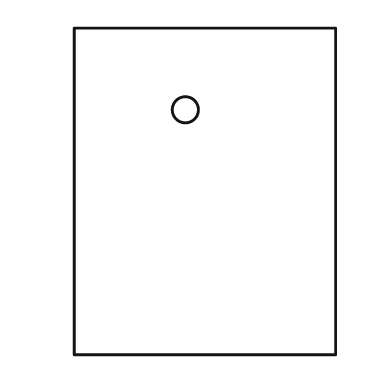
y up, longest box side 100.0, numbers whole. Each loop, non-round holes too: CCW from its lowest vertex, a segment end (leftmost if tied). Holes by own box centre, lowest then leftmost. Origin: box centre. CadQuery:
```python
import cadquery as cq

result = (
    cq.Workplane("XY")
    .moveTo(-40.0, -50.0)
    .lineTo(40.0, -50.0)
    .lineTo(40.0, 50.0)
    .lineTo(-40.0, 50.0)
    .close()
    .moveTo(-6.0, 25.0)
    .circle(4.0)
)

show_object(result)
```